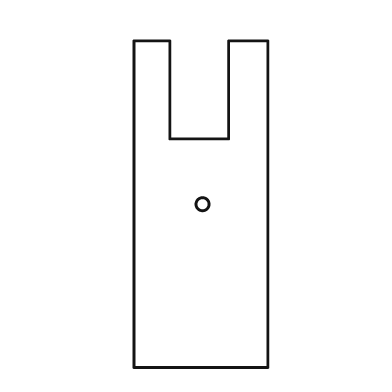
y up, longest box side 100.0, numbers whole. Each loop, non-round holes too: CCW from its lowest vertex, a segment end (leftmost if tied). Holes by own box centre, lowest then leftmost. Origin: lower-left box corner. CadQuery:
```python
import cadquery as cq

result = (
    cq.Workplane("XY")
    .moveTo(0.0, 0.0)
    .lineTo(41.0, 0.0)
    .lineTo(41.0, 100.0)
    .lineTo(29.0, 100.0)
    .lineTo(29.0, 70.0)
    .lineTo(11.0, 70.0)
    .lineTo(11.0, 100.0)
    .lineTo(0.0, 100.0)
    .close()
    .moveTo(21.0, 50.0)
    .circle(2.0)
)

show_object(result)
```